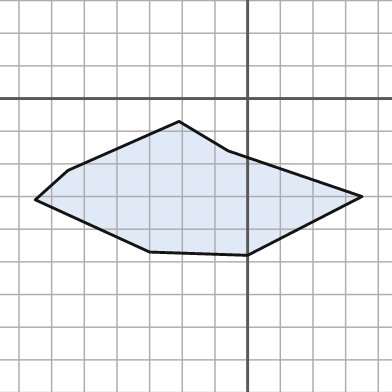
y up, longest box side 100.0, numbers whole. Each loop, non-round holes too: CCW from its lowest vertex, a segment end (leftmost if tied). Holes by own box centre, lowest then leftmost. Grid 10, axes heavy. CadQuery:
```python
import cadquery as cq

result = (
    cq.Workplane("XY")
    .moveTo(0.0, -48.0)
    .lineTo(35.0, -30.0)
    .lineTo(-6.0, -16.0)
    .lineTo(-21.0, -7.0)
    .lineTo(-55.0, -22.0)
    .lineTo(-65.0, -31.0)
    .lineTo(-30.0, -47.0)
    .close()
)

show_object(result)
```